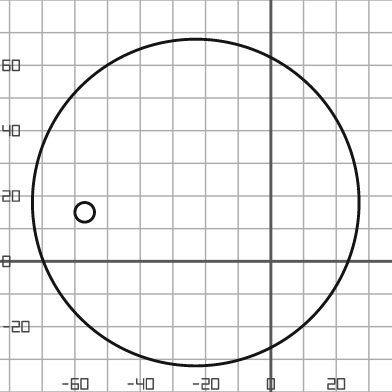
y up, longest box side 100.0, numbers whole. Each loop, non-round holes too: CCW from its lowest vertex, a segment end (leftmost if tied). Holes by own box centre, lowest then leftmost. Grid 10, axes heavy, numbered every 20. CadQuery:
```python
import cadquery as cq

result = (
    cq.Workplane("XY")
    .moveTo(-23.0, 18.0)
    .circle(50.0)
    .moveTo(-57.0, 15.0)
    .circle(3.0)
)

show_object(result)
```